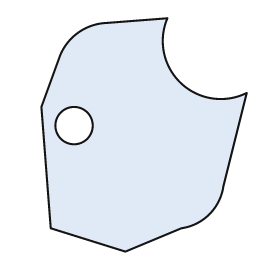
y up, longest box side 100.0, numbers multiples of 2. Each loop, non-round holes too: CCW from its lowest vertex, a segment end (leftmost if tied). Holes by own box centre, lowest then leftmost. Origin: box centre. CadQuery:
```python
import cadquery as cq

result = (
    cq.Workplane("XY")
    .moveTo(-8.0, -50.0)
    .lineTo(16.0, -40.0)
    .threePointArc((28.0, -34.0), (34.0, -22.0))
    .lineTo(44.0, 18.0)
    .threePointArc((16.0, 22.0), (10.0, 50.0))
    .lineTo(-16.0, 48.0)
    .threePointArc((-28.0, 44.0), (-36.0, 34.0))
    .lineTo(-44.0, 12.0)
    .lineTo(-40.0, -40.0)
    .close()
    .moveTo(-30.0, 4.0)
    .circle(8.0)
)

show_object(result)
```